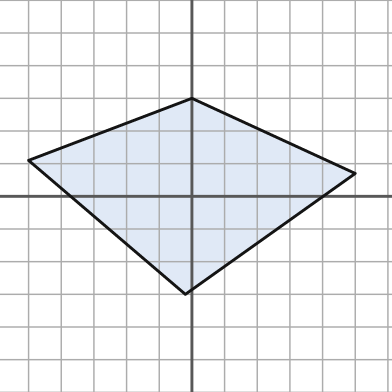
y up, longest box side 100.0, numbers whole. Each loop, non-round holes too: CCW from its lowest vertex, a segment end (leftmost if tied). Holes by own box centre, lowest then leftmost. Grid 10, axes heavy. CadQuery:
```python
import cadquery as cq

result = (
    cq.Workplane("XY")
    .moveTo(-2.0, -30.0)
    .lineTo(50.0, 7.0)
    .lineTo(0.0, 30.0)
    .lineTo(-50.0, 11.0)
    .close()
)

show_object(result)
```